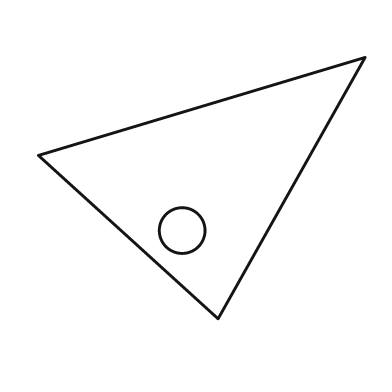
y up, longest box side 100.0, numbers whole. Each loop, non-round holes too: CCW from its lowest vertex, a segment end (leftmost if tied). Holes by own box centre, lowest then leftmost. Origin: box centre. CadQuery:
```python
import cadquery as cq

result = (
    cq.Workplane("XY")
    .moveTo(5.0, -40.0)
    .lineTo(50.0, 40.0)
    .lineTo(-50.0, 10.0)
    .close()
    .moveTo(-6.0, -13.0)
    .circle(7.0)
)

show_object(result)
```